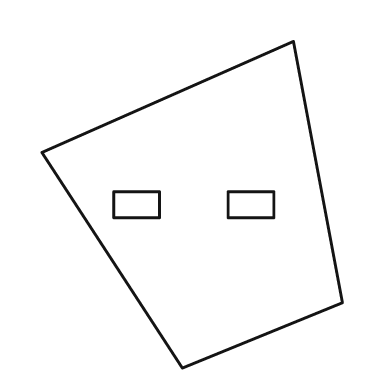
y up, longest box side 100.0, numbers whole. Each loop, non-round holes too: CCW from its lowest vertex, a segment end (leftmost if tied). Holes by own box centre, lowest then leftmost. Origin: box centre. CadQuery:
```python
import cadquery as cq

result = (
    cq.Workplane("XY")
    .moveTo(-3.0, -50.0)
    .lineTo(46.0, -30.0)
    .lineTo(31.0, 50.0)
    .lineTo(-46.0, 16.0)
    .close()
    .moveTo(-24.0, -4.0)
    .lineTo(-10.0, -4.0)
    .lineTo(-10.0, 4.0)
    .lineTo(-24.0, 4.0)
    .close()
    .moveTo(11.0, -4.0)
    .lineTo(25.0, -4.0)
    .lineTo(25.0, 4.0)
    .lineTo(11.0, 4.0)
    .close()
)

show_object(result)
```